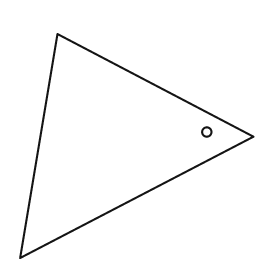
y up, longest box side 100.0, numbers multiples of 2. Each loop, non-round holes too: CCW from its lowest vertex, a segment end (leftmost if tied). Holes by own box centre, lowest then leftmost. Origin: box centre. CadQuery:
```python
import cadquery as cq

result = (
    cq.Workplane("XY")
    .moveTo(-50.0, -48.0)
    .lineTo(50.0, 4.0)
    .lineTo(-34.0, 48.0)
    .close()
    .moveTo(30.0, 6.0)
    .circle(2.0)
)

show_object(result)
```